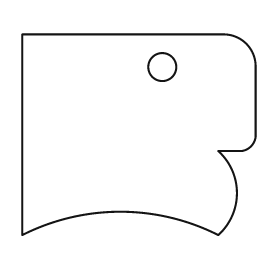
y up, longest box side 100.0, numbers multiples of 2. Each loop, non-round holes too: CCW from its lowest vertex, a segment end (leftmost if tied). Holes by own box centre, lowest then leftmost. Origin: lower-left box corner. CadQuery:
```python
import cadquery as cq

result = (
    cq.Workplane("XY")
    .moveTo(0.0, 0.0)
    .threePointArc((42.0, 10.0), (84.0, 0.0))
    .threePointArc((92.0, 18.0), (84.0, 36.0))
    .lineTo(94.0, 36.0)
    .threePointArc((98.0, 38.0), (100.0, 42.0))
    .lineTo(100.0, 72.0)
    .threePointArc((96.0, 82.0), (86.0, 86.0))
    .lineTo(0.0, 86.0)
    .close()
    .moveTo(60.0, 72.0)
    .circle(6.0)
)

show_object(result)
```